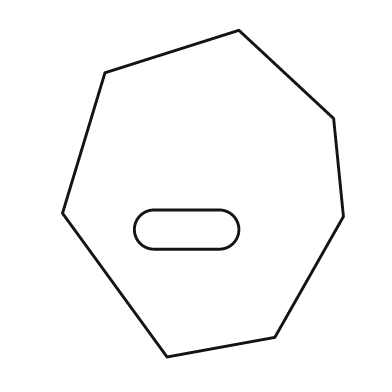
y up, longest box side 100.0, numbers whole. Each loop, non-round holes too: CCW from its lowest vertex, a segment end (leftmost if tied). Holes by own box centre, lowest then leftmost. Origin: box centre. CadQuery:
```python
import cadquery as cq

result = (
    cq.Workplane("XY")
    .moveTo(-11.0, -50.0)
    .lineTo(22.0, -44.0)
    .lineTo(43.0, -7.0)
    .lineTo(40.0, 23.0)
    .lineTo(11.0, 50.0)
    .lineTo(-30.0, 37.0)
    .lineTo(-43.0, -6.0)
    .close()
    .moveTo(-15.0, -17.0)
    .lineTo(5.0, -17.0)
    .threePointArc((11.0, -11.0), (5.0, -5.0))
    .lineTo(-15.0, -5.0)
    .threePointArc((-21.0, -11.0), (-15.0, -17.0))
    .close()
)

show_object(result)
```